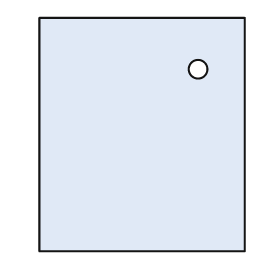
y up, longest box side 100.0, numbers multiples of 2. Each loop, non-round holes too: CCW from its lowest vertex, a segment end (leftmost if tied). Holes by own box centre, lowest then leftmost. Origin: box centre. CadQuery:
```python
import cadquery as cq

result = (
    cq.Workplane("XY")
    .moveTo(-44.0, -50.0)
    .lineTo(44.0, -50.0)
    .lineTo(44.0, 50.0)
    .lineTo(-44.0, 50.0)
    .close()
    .moveTo(24.0, 28.0)
    .circle(4.0)
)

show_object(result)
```